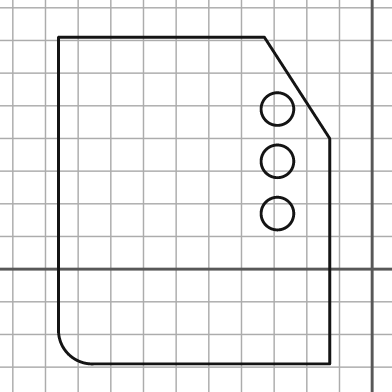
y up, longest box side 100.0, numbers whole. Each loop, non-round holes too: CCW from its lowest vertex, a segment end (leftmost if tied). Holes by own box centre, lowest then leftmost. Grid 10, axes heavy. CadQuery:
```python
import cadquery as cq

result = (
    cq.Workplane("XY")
    .moveTo(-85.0, -29.0)
    .lineTo(-13.0, -29.0)
    .lineTo(-13.0, 40.0)
    .lineTo(-33.0, 71.0)
    .lineTo(-96.0, 71.0)
    .lineTo(-96.0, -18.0)
    .threePointArc((-93.0, -26.0), (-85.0, -29.0))
    .close()
    .moveTo(-29.0, 17.0)
    .circle(5.0)
    .moveTo(-29.0, 33.0)
    .circle(5.0)
    .moveTo(-29.0, 49.0)
    .circle(5.0)
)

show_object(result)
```